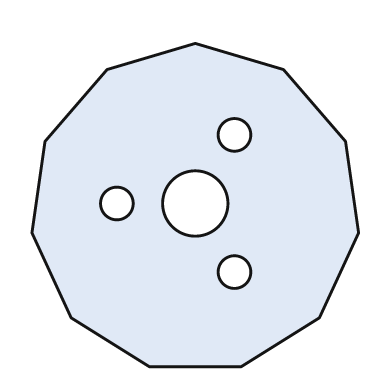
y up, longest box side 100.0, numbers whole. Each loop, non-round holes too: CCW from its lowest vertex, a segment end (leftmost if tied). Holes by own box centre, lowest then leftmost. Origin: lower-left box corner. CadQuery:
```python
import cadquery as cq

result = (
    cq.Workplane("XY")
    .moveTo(36.0, 0.0)
    .lineTo(64.0, 0.0)
    .lineTo(88.0, 15.0)
    .lineTo(100.0, 41.0)
    .lineTo(96.0, 69.0)
    .lineTo(77.0, 91.0)
    .lineTo(50.0, 99.0)
    .lineTo(23.0, 91.0)
    .lineTo(4.0, 69.0)
    .lineTo(0.0, 41.0)
    .lineTo(12.0, 15.0)
    .close()
    .moveTo(62.0, 29.0)
    .circle(5.0)
    .moveTo(26.0, 50.0)
    .circle(5.0)
    .moveTo(50.0, 50.0)
    .circle(10.0)
    .moveTo(62.0, 71.0)
    .circle(5.0)
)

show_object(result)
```